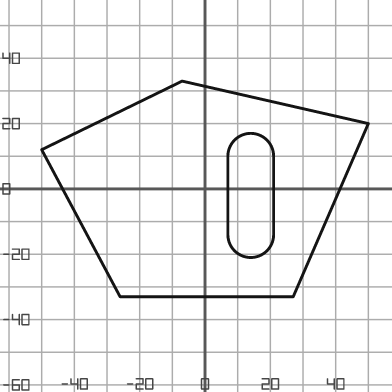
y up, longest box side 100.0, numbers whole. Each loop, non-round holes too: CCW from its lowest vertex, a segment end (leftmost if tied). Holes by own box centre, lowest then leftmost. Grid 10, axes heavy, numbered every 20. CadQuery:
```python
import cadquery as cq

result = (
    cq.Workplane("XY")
    .moveTo(-26.0, -33.0)
    .lineTo(27.0, -33.0)
    .lineTo(50.0, 20.0)
    .lineTo(-7.0, 33.0)
    .lineTo(-50.0, 12.0)
    .close()
    .moveTo(7.0, -14.0)
    .threePointArc((14.0, -21.0), (21.0, -14.0))
    .lineTo(21.0, 10.0)
    .threePointArc((14.0, 17.0), (7.0, 10.0))
    .close()
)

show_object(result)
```